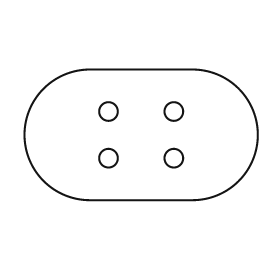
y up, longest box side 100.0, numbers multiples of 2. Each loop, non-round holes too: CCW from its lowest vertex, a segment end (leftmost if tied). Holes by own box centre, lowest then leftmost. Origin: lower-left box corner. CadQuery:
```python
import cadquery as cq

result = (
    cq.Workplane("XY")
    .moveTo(28.0, 0.0)
    .lineTo(72.0, 0.0)
    .threePointArc((100.0, 28.0), (72.0, 56.0))
    .lineTo(28.0, 56.0)
    .threePointArc((0.0, 28.0), (28.0, 0.0))
    .close()
    .moveTo(36.0, 18.0)
    .circle(4.0)
    .moveTo(64.0, 18.0)
    .circle(4.0)
    .moveTo(36.0, 38.0)
    .circle(4.0)
    .moveTo(64.0, 38.0)
    .circle(4.0)
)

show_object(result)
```